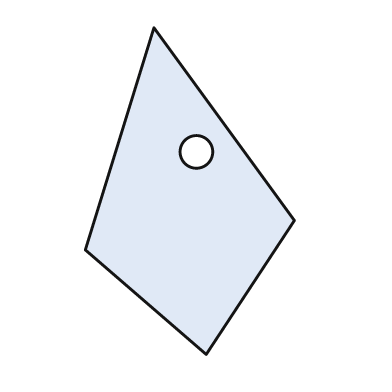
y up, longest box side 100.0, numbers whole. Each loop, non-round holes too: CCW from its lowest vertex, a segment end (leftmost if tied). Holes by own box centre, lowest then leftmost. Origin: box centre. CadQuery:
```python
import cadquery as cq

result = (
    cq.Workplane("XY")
    .moveTo(5.0, -50.0)
    .lineTo(32.0, -9.0)
    .lineTo(-11.0, 50.0)
    .lineTo(-32.0, -18.0)
    .close()
    .moveTo(2.0, 12.0)
    .circle(5.0)
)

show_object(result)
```